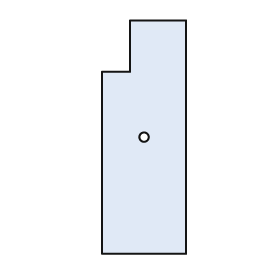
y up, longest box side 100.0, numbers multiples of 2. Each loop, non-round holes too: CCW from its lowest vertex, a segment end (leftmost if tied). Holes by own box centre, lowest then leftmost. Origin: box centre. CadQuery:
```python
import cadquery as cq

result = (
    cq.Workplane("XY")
    .moveTo(-18.0, -50.0)
    .lineTo(18.0, -50.0)
    .lineTo(18.0, 50.0)
    .lineTo(-6.0, 50.0)
    .lineTo(-6.0, 28.0)
    .lineTo(-18.0, 28.0)
    .close()
    .moveTo(0.0, 0.0)
    .circle(2.0)
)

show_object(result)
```